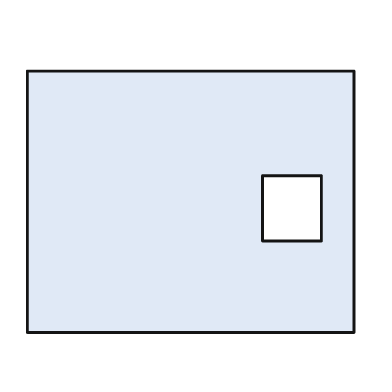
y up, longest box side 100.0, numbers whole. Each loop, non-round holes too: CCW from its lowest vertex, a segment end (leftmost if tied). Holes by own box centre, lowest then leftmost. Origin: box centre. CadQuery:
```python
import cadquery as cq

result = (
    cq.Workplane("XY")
    .moveTo(-50.0, -40.0)
    .lineTo(50.0, -40.0)
    .lineTo(50.0, 40.0)
    .lineTo(-50.0, 40.0)
    .close()
    .moveTo(22.0, -12.0)
    .lineTo(40.0, -12.0)
    .lineTo(40.0, 8.0)
    .lineTo(22.0, 8.0)
    .close()
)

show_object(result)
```